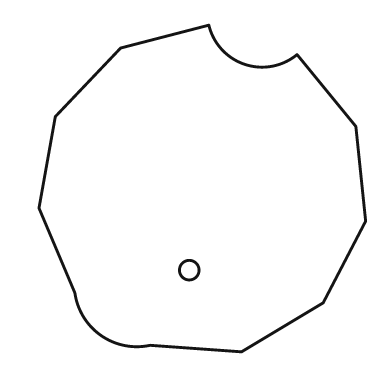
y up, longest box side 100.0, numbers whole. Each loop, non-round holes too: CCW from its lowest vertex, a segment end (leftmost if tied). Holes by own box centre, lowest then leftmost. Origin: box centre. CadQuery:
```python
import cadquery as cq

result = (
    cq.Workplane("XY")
    .moveTo(12.0, -50.0)
    .lineTo(37.0, -35.0)
    .lineTo(50.0, -10.0)
    .lineTo(47.0, 19.0)
    .lineTo(29.0, 41.0)
    .threePointArc((13.0, 38.0), (2.0, 50.0))
    .lineTo(-25.0, 43.0)
    .lineTo(-45.0, 22.0)
    .lineTo(-50.0, -6.0)
    .lineTo(-39.0, -32.0)
    .threePointArc((-31.0, -45.0), (-16.0, -48.0))
    .close()
    .moveTo(-4.0, -25.0)
    .circle(3.0)
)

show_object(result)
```